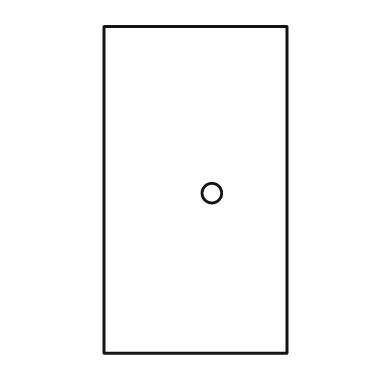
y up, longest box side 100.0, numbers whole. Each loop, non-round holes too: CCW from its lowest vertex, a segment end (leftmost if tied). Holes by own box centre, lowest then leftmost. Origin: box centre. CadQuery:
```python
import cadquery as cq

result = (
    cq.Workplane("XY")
    .moveTo(-28.0, -50.0)
    .lineTo(28.0, -50.0)
    .lineTo(28.0, 50.0)
    .lineTo(-28.0, 50.0)
    .close()
    .moveTo(5.0, -1.0)
    .circle(3.0)
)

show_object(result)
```